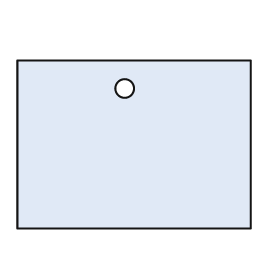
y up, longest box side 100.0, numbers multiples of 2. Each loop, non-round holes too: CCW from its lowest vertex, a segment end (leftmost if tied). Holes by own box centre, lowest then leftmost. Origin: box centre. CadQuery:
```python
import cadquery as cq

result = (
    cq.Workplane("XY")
    .moveTo(-50.0, -36.0)
    .lineTo(50.0, -36.0)
    .lineTo(50.0, 36.0)
    .lineTo(-50.0, 36.0)
    .close()
    .moveTo(-4.0, 24.0)
    .circle(4.0)
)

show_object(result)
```